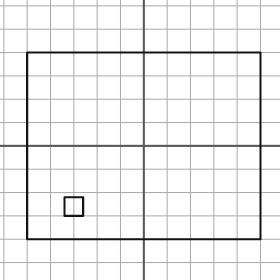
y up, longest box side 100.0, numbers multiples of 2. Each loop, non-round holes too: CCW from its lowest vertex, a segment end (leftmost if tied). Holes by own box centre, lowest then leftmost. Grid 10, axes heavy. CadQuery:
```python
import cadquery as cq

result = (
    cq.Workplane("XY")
    .moveTo(-50.0, -40.0)
    .lineTo(50.0, -40.0)
    .lineTo(50.0, 40.0)
    .lineTo(-50.0, 40.0)
    .close()
    .moveTo(-34.0, -30.0)
    .lineTo(-26.0, -30.0)
    .lineTo(-26.0, -22.0)
    .lineTo(-34.0, -22.0)
    .close()
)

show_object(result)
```